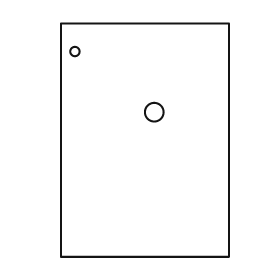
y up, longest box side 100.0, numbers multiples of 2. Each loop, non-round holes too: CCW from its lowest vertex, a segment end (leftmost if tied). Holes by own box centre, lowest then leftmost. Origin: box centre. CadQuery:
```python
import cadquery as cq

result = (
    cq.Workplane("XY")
    .moveTo(-36.0, -50.0)
    .lineTo(36.0, -50.0)
    .lineTo(36.0, 50.0)
    .lineTo(-36.0, 50.0)
    .close()
    .moveTo(4.0, 12.0)
    .circle(4.0)
    .moveTo(-30.0, 38.0)
    .circle(2.0)
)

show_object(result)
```